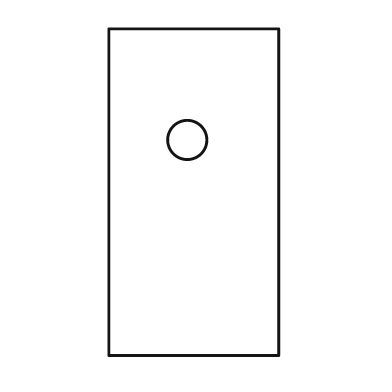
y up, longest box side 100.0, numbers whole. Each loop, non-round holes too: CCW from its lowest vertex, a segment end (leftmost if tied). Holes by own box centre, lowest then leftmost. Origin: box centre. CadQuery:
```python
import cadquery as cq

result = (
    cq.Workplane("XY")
    .moveTo(-26.0, -50.0)
    .lineTo(26.0, -50.0)
    .lineTo(26.0, 50.0)
    .lineTo(-26.0, 50.0)
    .close()
    .moveTo(-2.0, 16.0)
    .circle(6.0)
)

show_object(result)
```